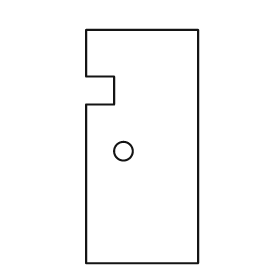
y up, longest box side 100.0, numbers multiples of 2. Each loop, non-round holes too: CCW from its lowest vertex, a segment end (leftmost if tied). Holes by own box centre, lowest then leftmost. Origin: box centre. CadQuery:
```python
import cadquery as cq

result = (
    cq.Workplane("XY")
    .moveTo(-24.0, -50.0)
    .lineTo(24.0, -50.0)
    .lineTo(24.0, 50.0)
    .lineTo(-24.0, 50.0)
    .lineTo(-24.0, 30.0)
    .lineTo(-12.0, 30.0)
    .lineTo(-12.0, 18.0)
    .lineTo(-24.0, 18.0)
    .close()
    .moveTo(-8.0, -2.0)
    .circle(4.0)
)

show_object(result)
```